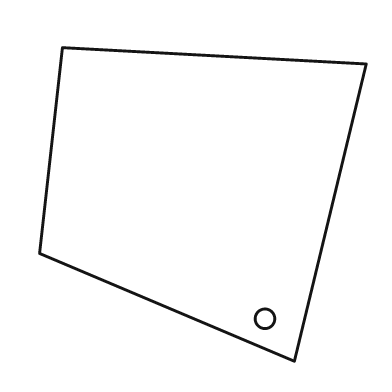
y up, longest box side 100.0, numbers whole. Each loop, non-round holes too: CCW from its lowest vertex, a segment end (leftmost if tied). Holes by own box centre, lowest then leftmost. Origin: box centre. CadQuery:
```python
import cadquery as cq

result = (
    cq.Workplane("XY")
    .moveTo(28.0, -48.0)
    .lineTo(50.0, 43.0)
    .lineTo(-43.0, 48.0)
    .lineTo(-50.0, -15.0)
    .close()
    .moveTo(19.0, -35.0)
    .circle(3.0)
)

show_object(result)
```